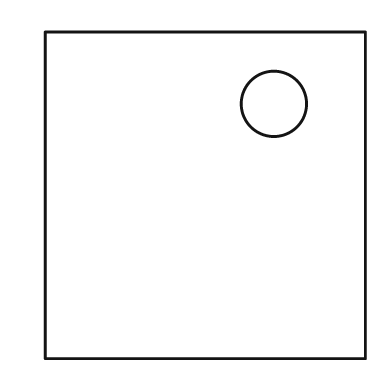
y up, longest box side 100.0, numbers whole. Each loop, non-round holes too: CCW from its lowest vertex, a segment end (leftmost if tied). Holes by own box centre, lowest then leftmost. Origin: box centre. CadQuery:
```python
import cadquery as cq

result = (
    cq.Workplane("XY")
    .moveTo(-49.0, -50.0)
    .lineTo(49.0, -50.0)
    .lineTo(49.0, 50.0)
    .lineTo(-49.0, 50.0)
    .close()
    .moveTo(21.0, 28.0)
    .circle(10.0)
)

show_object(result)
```